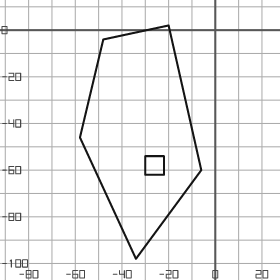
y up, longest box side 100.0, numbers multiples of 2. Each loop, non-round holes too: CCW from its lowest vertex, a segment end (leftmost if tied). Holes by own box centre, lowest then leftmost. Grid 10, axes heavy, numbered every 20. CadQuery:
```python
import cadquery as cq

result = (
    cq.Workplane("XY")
    .moveTo(-34.0, -98.0)
    .lineTo(-6.0, -60.0)
    .lineTo(-20.0, 2.0)
    .lineTo(-48.0, -4.0)
    .lineTo(-58.0, -46.0)
    .close()
    .moveTo(-30.0, -62.0)
    .lineTo(-22.0, -62.0)
    .lineTo(-22.0, -54.0)
    .lineTo(-30.0, -54.0)
    .close()
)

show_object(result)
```